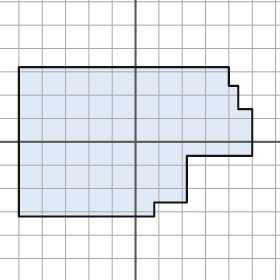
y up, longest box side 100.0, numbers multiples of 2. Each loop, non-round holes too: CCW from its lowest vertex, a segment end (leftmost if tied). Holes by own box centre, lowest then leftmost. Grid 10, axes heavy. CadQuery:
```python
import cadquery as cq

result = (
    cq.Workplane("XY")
    .moveTo(-50.0, -32.0)
    .lineTo(8.0, -32.0)
    .lineTo(8.0, -26.0)
    .lineTo(22.0, -26.0)
    .lineTo(22.0, -6.0)
    .lineTo(50.0, -6.0)
    .lineTo(50.0, 14.0)
    .lineTo(44.0, 14.0)
    .lineTo(44.0, 24.0)
    .lineTo(40.0, 24.0)
    .lineTo(40.0, 32.0)
    .lineTo(-50.0, 32.0)
    .close()
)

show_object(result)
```